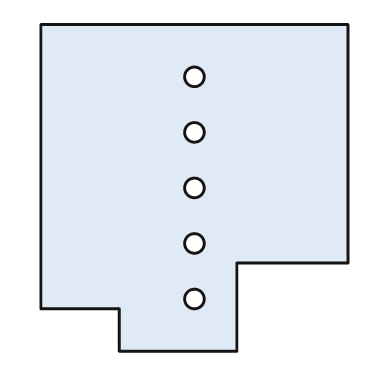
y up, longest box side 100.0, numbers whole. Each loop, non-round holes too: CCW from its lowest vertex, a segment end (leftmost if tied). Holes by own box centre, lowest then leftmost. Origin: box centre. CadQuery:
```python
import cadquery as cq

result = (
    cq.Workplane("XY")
    .moveTo(-23.0, -50.0)
    .lineTo(13.0, -50.0)
    .lineTo(13.0, -23.0)
    .lineTo(47.0, -23.0)
    .lineTo(47.0, 50.0)
    .lineTo(-47.0, 50.0)
    .lineTo(-47.0, -37.0)
    .lineTo(-23.0, -37.0)
    .close()
    .moveTo(0.0, -34.0)
    .circle(3.0)
    .moveTo(0.0, -17.0)
    .circle(3.0)
    .moveTo(0.0, 0.0)
    .circle(3.0)
    .moveTo(0.0, 17.0)
    .circle(3.0)
    .moveTo(0.0, 34.0)
    .circle(3.0)
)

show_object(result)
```